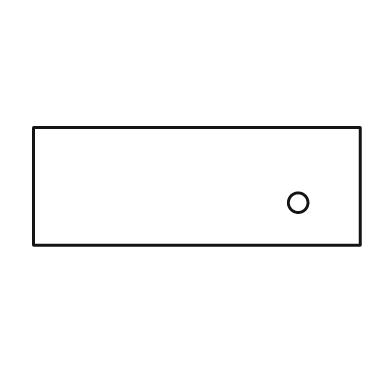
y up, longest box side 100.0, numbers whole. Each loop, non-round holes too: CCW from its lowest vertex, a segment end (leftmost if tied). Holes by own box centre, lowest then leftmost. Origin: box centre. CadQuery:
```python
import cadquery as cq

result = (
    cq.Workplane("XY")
    .moveTo(-50.0, -18.0)
    .lineTo(50.0, -18.0)
    .lineTo(50.0, 18.0)
    .lineTo(-50.0, 18.0)
    .close()
    .moveTo(31.0, -5.0)
    .circle(3.0)
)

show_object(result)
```